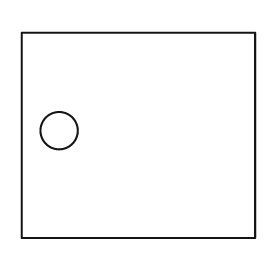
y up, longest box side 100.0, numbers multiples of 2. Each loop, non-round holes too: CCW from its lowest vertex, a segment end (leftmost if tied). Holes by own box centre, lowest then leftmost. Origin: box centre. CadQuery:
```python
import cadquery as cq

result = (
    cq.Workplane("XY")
    .moveTo(-50.0, -44.0)
    .lineTo(50.0, -44.0)
    .lineTo(50.0, 44.0)
    .lineTo(-50.0, 44.0)
    .close()
    .moveTo(-34.0, 2.0)
    .circle(8.0)
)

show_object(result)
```